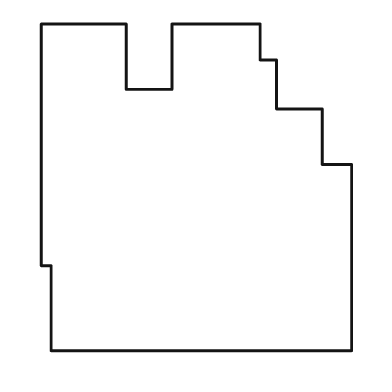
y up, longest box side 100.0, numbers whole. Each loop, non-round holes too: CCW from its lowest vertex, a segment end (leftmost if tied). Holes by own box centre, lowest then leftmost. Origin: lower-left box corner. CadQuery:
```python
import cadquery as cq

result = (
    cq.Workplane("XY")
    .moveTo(3.0, 0.0)
    .lineTo(95.0, 0.0)
    .lineTo(95.0, 57.0)
    .lineTo(86.0, 57.0)
    .lineTo(86.0, 74.0)
    .lineTo(72.0, 74.0)
    .lineTo(72.0, 89.0)
    .lineTo(67.0, 89.0)
    .lineTo(67.0, 100.0)
    .lineTo(40.0, 100.0)
    .lineTo(40.0, 80.0)
    .lineTo(26.0, 80.0)
    .lineTo(26.0, 100.0)
    .lineTo(0.0, 100.0)
    .lineTo(0.0, 26.0)
    .lineTo(3.0, 26.0)
    .close()
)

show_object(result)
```